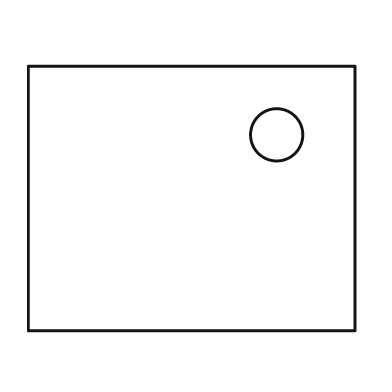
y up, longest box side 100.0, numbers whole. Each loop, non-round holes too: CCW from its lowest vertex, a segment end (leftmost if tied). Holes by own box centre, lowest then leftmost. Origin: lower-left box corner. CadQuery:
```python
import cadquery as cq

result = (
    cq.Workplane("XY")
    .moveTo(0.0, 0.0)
    .lineTo(100.0, 0.0)
    .lineTo(100.0, 81.0)
    .lineTo(0.0, 81.0)
    .close()
    .moveTo(76.0, 60.0)
    .circle(8.0)
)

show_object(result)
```